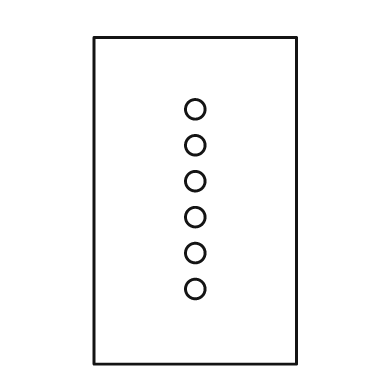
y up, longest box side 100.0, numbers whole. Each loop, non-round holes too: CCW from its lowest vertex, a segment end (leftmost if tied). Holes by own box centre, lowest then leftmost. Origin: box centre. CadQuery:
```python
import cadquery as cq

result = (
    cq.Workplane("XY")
    .moveTo(-31.0, -50.0)
    .lineTo(31.0, -50.0)
    .lineTo(31.0, 50.0)
    .lineTo(-31.0, 50.0)
    .close()
    .moveTo(0.0, -27.0)
    .circle(3.0)
    .moveTo(0.0, -16.0)
    .circle(3.0)
    .moveTo(0.0, -5.0)
    .circle(3.0)
    .moveTo(0.0, 6.0)
    .circle(3.0)
    .moveTo(0.0, 17.0)
    .circle(3.0)
    .moveTo(0.0, 28.0)
    .circle(3.0)
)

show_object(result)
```